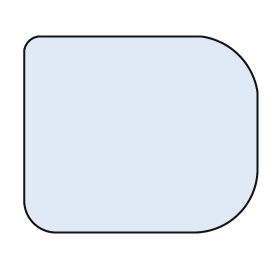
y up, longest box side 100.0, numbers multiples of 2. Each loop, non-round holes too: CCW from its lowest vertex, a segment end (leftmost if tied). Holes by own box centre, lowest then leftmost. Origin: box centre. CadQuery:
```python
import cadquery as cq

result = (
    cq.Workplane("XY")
    .moveTo(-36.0, -42.0)
    .lineTo(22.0, -42.0)
    .threePointArc((42.0, -34.0), (50.0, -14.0))
    .lineTo(50.0, 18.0)
    .threePointArc((42.0, 34.0), (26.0, 42.0))
    .lineTo(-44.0, 42.0)
    .threePointArc((-48.0, 40.0), (-50.0, 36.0))
    .lineTo(-50.0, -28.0)
    .threePointArc((-46.0, -38.0), (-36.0, -42.0))
    .close()
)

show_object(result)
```